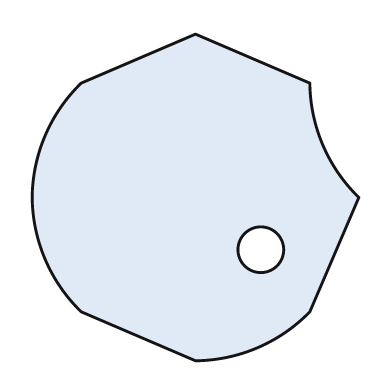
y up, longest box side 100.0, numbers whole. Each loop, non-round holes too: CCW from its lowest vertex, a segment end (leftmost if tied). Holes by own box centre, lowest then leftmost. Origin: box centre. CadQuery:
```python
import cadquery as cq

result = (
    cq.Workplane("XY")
    .moveTo(0.0, -50.0)
    .threePointArc((19.0, -46.0), (35.0, -35.0))
    .lineTo(50.0, 0.0)
    .threePointArc((39.0, 16.0), (35.0, 35.0))
    .lineTo(0.0, 50.0)
    .lineTo(-35.0, 35.0)
    .threePointArc((-46.0, 19.0), (-50.0, 0.0))
    .threePointArc((-46.0, -19.0), (-35.0, -35.0))
    .close()
    .moveTo(20.0, -16.0)
    .circle(7.0)
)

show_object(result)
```